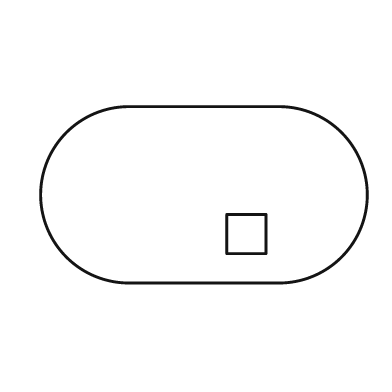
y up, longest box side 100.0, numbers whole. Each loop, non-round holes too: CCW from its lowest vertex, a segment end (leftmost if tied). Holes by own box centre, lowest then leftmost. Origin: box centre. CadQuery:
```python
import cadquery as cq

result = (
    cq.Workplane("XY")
    .moveTo(-23.0, -27.0)
    .lineTo(23.0, -27.0)
    .threePointArc((50.0, 0.0), (23.0, 27.0))
    .lineTo(-23.0, 27.0)
    .threePointArc((-50.0, 0.0), (-23.0, -27.0))
    .close()
    .moveTo(7.0, -18.0)
    .lineTo(19.0, -18.0)
    .lineTo(19.0, -6.0)
    .lineTo(7.0, -6.0)
    .close()
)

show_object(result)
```